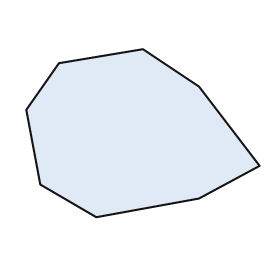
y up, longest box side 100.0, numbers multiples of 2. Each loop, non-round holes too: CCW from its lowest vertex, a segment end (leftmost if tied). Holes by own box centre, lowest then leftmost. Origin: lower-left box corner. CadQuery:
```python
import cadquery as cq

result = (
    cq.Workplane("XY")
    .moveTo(30.0, 0.0)
    .lineTo(74.0, 8.0)
    .lineTo(100.0, 22.0)
    .lineTo(74.0, 56.0)
    .lineTo(50.0, 72.0)
    .lineTo(14.0, 66.0)
    .lineTo(0.0, 46.0)
    .lineTo(6.0, 14.0)
    .close()
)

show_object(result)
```